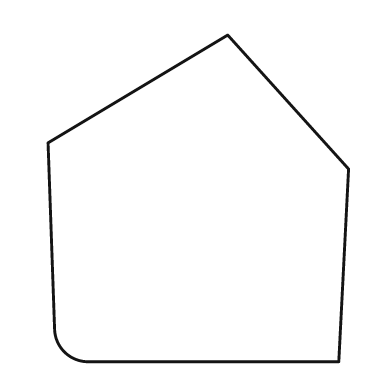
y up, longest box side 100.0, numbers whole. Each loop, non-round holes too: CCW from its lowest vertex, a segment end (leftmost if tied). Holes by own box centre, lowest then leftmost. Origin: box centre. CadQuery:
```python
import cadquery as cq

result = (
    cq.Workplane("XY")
    .moveTo(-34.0, -50.0)
    .lineTo(43.0, -50.0)
    .lineTo(46.0, 9.0)
    .lineTo(9.0, 50.0)
    .lineTo(-46.0, 17.0)
    .lineTo(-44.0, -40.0)
    .threePointArc((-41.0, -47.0), (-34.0, -50.0))
    .close()
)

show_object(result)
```